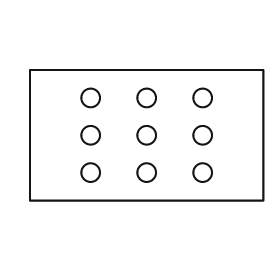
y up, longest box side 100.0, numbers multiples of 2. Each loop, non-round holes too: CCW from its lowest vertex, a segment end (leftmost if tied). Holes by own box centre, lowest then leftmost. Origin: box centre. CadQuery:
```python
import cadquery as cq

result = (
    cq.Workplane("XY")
    .moveTo(-50.0, -28.0)
    .lineTo(50.0, -28.0)
    .lineTo(50.0, 28.0)
    .lineTo(-50.0, 28.0)
    .close()
    .moveTo(-24.0, -16.0)
    .circle(4.0)
    .moveTo(0.0, -16.0)
    .circle(4.0)
    .moveTo(24.0, -16.0)
    .circle(4.0)
    .moveTo(-24.0, 0.0)
    .circle(4.0)
    .moveTo(0.0, 0.0)
    .circle(4.0)
    .moveTo(24.0, 0.0)
    .circle(4.0)
    .moveTo(-24.0, 16.0)
    .circle(4.0)
    .moveTo(0.0, 16.0)
    .circle(4.0)
    .moveTo(24.0, 16.0)
    .circle(4.0)
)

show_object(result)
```